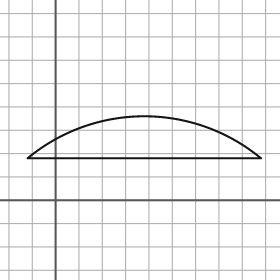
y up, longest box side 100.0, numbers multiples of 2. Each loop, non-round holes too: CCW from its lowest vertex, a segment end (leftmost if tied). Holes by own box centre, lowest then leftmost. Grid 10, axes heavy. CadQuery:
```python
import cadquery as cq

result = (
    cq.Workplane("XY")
    .moveTo(-12.0, 18.0)
    .lineTo(88.0, 18.0)
    .threePointArc((38.0, 36.0), (-12.0, 18.0))
    .close()
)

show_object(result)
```